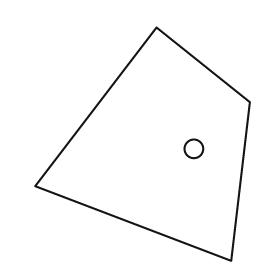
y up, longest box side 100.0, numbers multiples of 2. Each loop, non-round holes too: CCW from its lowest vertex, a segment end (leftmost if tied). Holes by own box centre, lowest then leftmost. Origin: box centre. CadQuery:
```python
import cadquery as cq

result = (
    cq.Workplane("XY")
    .moveTo(38.0, -50.0)
    .lineTo(46.0, 18.0)
    .lineTo(6.0, 50.0)
    .lineTo(-46.0, -18.0)
    .close()
    .moveTo(22.0, -2.0)
    .circle(4.0)
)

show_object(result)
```